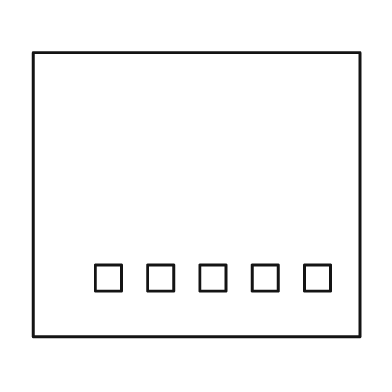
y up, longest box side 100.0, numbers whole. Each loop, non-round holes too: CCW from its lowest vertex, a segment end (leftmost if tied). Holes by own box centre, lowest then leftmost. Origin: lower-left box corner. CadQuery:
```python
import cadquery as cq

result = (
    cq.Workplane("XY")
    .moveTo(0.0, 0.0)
    .lineTo(100.0, 0.0)
    .lineTo(100.0, 87.0)
    .lineTo(0.0, 87.0)
    .close()
    .moveTo(19.0, 14.0)
    .lineTo(27.0, 14.0)
    .lineTo(27.0, 22.0)
    .lineTo(19.0, 22.0)
    .close()
    .moveTo(35.0, 14.0)
    .lineTo(43.0, 14.0)
    .lineTo(43.0, 22.0)
    .lineTo(35.0, 22.0)
    .close()
    .moveTo(51.0, 14.0)
    .lineTo(59.0, 14.0)
    .lineTo(59.0, 22.0)
    .lineTo(51.0, 22.0)
    .close()
    .moveTo(67.0, 14.0)
    .lineTo(75.0, 14.0)
    .lineTo(75.0, 22.0)
    .lineTo(67.0, 22.0)
    .close()
    .moveTo(83.0, 14.0)
    .lineTo(91.0, 14.0)
    .lineTo(91.0, 22.0)
    .lineTo(83.0, 22.0)
    .close()
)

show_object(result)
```